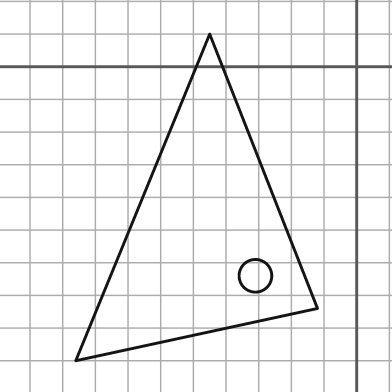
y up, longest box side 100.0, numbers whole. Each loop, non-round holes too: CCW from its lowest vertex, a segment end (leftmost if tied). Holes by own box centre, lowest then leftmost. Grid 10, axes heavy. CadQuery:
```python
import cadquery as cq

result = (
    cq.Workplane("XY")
    .moveTo(-86.0, -90.0)
    .lineTo(-12.0, -74.0)
    .lineTo(-45.0, 10.0)
    .close()
    .moveTo(-31.0, -64.0)
    .circle(5.0)
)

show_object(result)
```